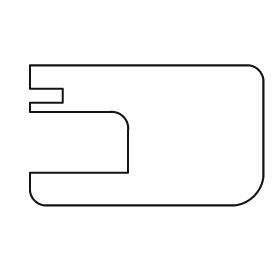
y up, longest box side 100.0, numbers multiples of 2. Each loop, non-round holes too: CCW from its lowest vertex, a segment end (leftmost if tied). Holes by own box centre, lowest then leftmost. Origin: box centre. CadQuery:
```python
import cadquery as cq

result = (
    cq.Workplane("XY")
    .moveTo(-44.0, -30.0)
    .lineTo(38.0, -30.0)
    .threePointArc((46.0, -26.0), (50.0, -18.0))
    .lineTo(50.0, 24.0)
    .threePointArc((48.0, 28.0), (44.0, 30.0))
    .lineTo(-50.0, 30.0)
    .lineTo(-50.0, 20.0)
    .lineTo(-36.0, 20.0)
    .lineTo(-36.0, 14.0)
    .lineTo(-50.0, 14.0)
    .lineTo(-50.0, 10.0)
    .lineTo(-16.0, 10.0)
    .threePointArc((-10.0, 8.0), (-8.0, 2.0))
    .lineTo(-8.0, -16.0)
    .lineTo(-50.0, -16.0)
    .lineTo(-50.0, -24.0)
    .threePointArc((-48.0, -28.0), (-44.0, -30.0))
    .close()
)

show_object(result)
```